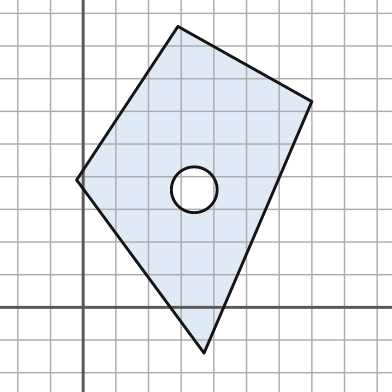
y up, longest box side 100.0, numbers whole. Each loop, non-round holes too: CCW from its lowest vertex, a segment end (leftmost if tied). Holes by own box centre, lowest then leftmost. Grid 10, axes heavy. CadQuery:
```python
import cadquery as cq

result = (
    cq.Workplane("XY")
    .moveTo(37.0, -14.0)
    .lineTo(70.0, 63.0)
    .lineTo(29.0, 86.0)
    .lineTo(-2.0, 39.0)
    .close()
    .moveTo(34.0, 36.0)
    .circle(7.0)
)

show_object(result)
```